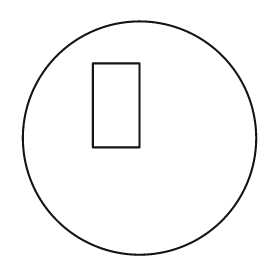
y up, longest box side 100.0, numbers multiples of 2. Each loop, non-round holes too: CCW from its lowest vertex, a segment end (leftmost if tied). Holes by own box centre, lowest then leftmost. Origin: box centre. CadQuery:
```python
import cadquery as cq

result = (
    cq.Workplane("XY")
    .moveTo(0.0, 0.0)
    .circle(50.0)
    .moveTo(-20.0, -4.0)
    .lineTo(0.0, -4.0)
    .lineTo(0.0, 32.0)
    .lineTo(-20.0, 32.0)
    .close()
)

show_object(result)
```